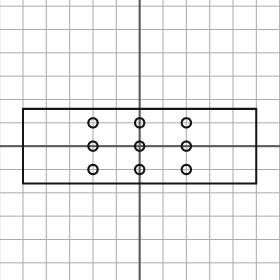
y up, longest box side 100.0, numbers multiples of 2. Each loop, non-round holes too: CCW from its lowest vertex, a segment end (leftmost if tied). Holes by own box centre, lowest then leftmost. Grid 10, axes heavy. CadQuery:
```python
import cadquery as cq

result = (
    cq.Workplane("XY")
    .moveTo(-50.0, -16.0)
    .lineTo(50.0, -16.0)
    .lineTo(50.0, 16.0)
    .lineTo(-50.0, 16.0)
    .close()
    .moveTo(-20.0, -10.0)
    .circle(2.0)
    .moveTo(0.0, -10.0)
    .circle(2.0)
    .moveTo(20.0, -10.0)
    .circle(2.0)
    .moveTo(-20.0, 0.0)
    .circle(2.0)
    .moveTo(0.0, 0.0)
    .circle(2.0)
    .moveTo(20.0, 0.0)
    .circle(2.0)
    .moveTo(-20.0, 10.0)
    .circle(2.0)
    .moveTo(0.0, 10.0)
    .circle(2.0)
    .moveTo(20.0, 10.0)
    .circle(2.0)
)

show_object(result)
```